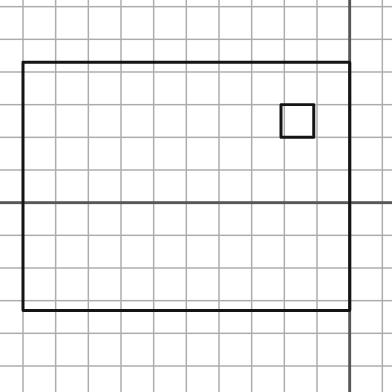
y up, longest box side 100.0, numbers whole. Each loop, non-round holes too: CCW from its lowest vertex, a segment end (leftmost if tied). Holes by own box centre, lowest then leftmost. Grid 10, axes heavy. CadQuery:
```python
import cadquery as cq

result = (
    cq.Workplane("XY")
    .moveTo(-100.0, -33.0)
    .lineTo(0.0, -33.0)
    .lineTo(0.0, 43.0)
    .lineTo(-100.0, 43.0)
    .close()
    .moveTo(-21.0, 20.0)
    .lineTo(-11.0, 20.0)
    .lineTo(-11.0, 30.0)
    .lineTo(-21.0, 30.0)
    .close()
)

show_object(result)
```